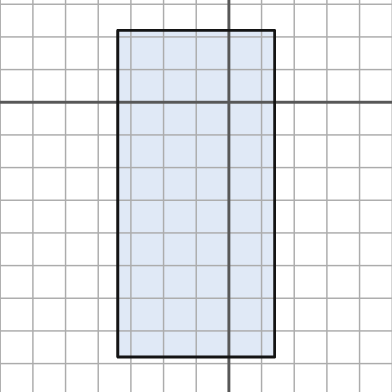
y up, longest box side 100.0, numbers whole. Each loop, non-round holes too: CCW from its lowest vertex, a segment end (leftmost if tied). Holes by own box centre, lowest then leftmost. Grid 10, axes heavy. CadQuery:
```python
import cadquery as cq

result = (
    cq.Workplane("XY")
    .moveTo(-34.0, -78.0)
    .lineTo(14.0, -78.0)
    .lineTo(14.0, 22.0)
    .lineTo(-34.0, 22.0)
    .close()
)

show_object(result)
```